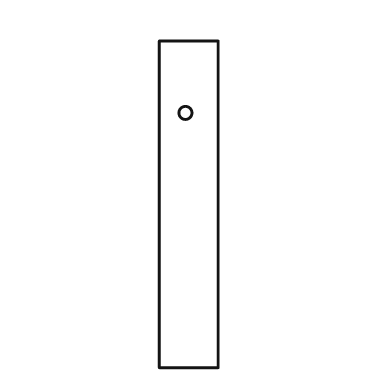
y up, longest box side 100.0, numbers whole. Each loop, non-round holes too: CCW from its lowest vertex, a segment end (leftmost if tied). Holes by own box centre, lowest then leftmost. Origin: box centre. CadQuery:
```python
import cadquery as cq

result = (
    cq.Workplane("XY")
    .moveTo(-9.0, -50.0)
    .lineTo(9.0, -50.0)
    .lineTo(9.0, 50.0)
    .lineTo(-9.0, 50.0)
    .close()
    .moveTo(-1.0, 28.0)
    .circle(2.0)
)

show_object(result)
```